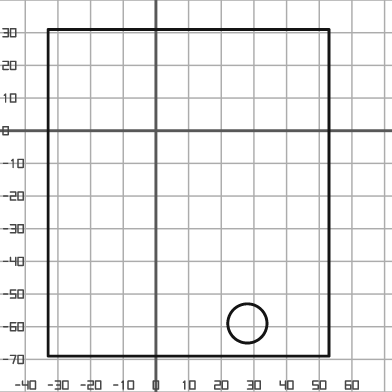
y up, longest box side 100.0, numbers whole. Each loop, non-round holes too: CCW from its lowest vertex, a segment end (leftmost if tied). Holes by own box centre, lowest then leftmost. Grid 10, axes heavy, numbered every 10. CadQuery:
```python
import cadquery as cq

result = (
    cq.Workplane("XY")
    .moveTo(-33.0, -69.0)
    .lineTo(53.0, -69.0)
    .lineTo(53.0, 31.0)
    .lineTo(-33.0, 31.0)
    .close()
    .moveTo(28.0, -59.0)
    .circle(6.0)
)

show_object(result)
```